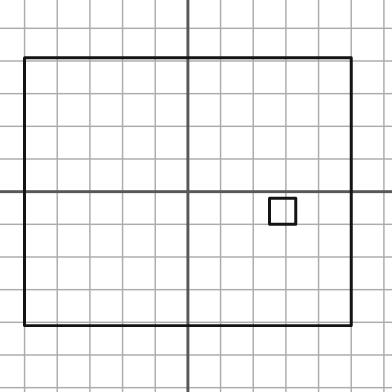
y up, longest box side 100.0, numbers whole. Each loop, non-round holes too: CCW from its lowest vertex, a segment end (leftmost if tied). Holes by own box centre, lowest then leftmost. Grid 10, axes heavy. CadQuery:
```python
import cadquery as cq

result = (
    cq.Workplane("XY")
    .moveTo(-50.0, -41.0)
    .lineTo(50.0, -41.0)
    .lineTo(50.0, 41.0)
    .lineTo(-50.0, 41.0)
    .close()
    .moveTo(25.0, -10.0)
    .lineTo(33.0, -10.0)
    .lineTo(33.0, -2.0)
    .lineTo(25.0, -2.0)
    .close()
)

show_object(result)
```